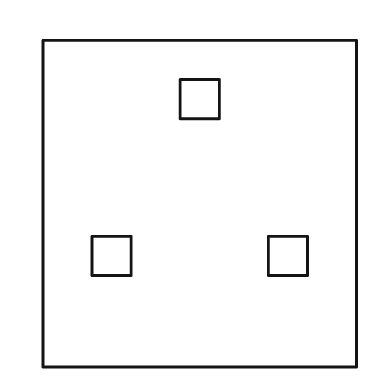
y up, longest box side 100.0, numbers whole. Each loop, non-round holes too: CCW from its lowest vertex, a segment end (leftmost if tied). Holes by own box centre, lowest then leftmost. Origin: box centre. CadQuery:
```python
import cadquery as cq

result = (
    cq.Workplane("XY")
    .moveTo(-48.0, -50.0)
    .lineTo(48.0, -50.0)
    .lineTo(48.0, 50.0)
    .lineTo(-48.0, 50.0)
    .close()
    .moveTo(-33.0, -22.0)
    .lineTo(-21.0, -22.0)
    .lineTo(-21.0, -10.0)
    .lineTo(-33.0, -10.0)
    .close()
    .moveTo(21.0, -22.0)
    .lineTo(33.0, -22.0)
    .lineTo(33.0, -10.0)
    .lineTo(21.0, -10.0)
    .close()
    .moveTo(-6.0, 26.0)
    .lineTo(6.0, 26.0)
    .lineTo(6.0, 38.0)
    .lineTo(-6.0, 38.0)
    .close()
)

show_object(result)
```